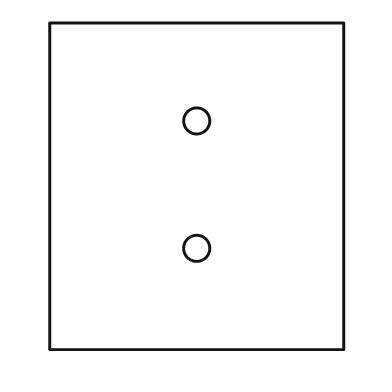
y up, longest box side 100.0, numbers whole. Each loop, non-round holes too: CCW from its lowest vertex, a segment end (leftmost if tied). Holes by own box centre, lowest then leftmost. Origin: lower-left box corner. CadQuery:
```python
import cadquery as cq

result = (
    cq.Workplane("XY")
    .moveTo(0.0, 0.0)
    .lineTo(90.0, 0.0)
    .lineTo(90.0, 100.0)
    .lineTo(0.0, 100.0)
    .close()
    .moveTo(45.0, 31.0)
    .circle(4.0)
    .moveTo(45.0, 70.0)
    .circle(4.0)
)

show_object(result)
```